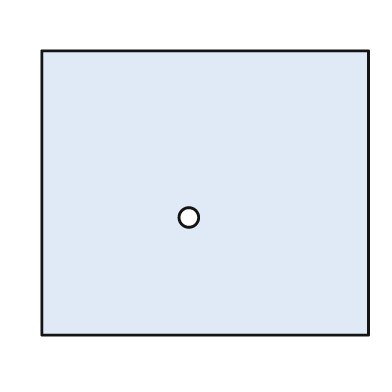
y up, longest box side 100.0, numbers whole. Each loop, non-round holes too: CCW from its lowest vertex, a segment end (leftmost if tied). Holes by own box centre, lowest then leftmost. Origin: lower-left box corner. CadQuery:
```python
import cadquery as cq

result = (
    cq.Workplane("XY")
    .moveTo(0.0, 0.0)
    .lineTo(100.0, 0.0)
    .lineTo(100.0, 87.0)
    .lineTo(0.0, 87.0)
    .close()
    .moveTo(45.0, 36.0)
    .circle(3.0)
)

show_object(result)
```